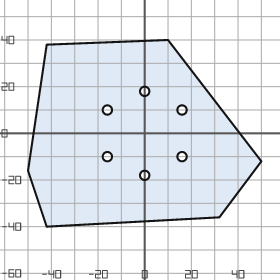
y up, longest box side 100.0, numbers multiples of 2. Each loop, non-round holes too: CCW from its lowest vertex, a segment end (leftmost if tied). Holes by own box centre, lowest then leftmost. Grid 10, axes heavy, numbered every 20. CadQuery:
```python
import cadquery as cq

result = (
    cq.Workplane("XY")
    .moveTo(-42.0, -40.0)
    .lineTo(32.0, -36.0)
    .lineTo(50.0, -12.0)
    .lineTo(10.0, 40.0)
    .lineTo(-42.0, 38.0)
    .lineTo(-50.0, -16.0)
    .close()
    .moveTo(0.0, -18.0)
    .circle(2.0)
    .moveTo(-16.0, -10.0)
    .circle(2.0)
    .moveTo(16.0, -10.0)
    .circle(2.0)
    .moveTo(-16.0, 10.0)
    .circle(2.0)
    .moveTo(16.0, 10.0)
    .circle(2.0)
    .moveTo(0.0, 18.0)
    .circle(2.0)
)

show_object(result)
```